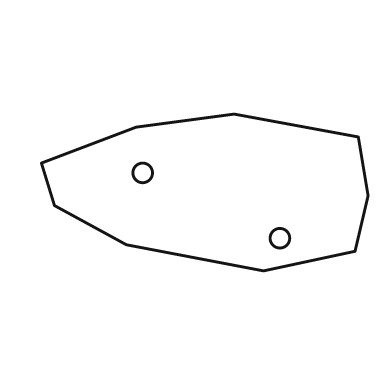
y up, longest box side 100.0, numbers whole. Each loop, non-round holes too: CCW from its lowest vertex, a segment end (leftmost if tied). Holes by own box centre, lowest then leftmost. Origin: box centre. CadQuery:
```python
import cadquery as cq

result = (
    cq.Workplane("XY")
    .moveTo(18.0, -24.0)
    .lineTo(46.0, -18.0)
    .lineTo(50.0, -1.0)
    .lineTo(47.0, 17.0)
    .lineTo(9.0, 24.0)
    .lineTo(-21.0, 20.0)
    .lineTo(-50.0, 9.0)
    .lineTo(-46.0, -4.0)
    .lineTo(-24.0, -16.0)
    .close()
    .moveTo(23.0, -14.0)
    .circle(3.0)
    .moveTo(-19.0, 6.0)
    .circle(3.0)
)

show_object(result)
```